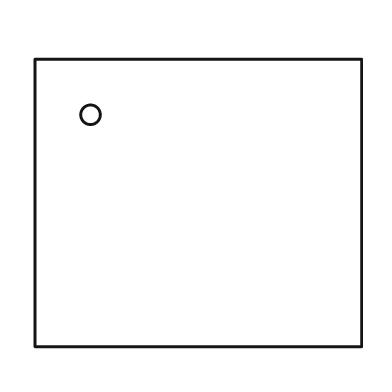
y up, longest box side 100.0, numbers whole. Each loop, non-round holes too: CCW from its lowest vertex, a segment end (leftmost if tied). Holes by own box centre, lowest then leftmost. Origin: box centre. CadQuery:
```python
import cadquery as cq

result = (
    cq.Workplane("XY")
    .moveTo(-50.0, -44.0)
    .lineTo(50.0, -44.0)
    .lineTo(50.0, 44.0)
    .lineTo(-50.0, 44.0)
    .close()
    .moveTo(-33.0, 27.0)
    .circle(3.0)
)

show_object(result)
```